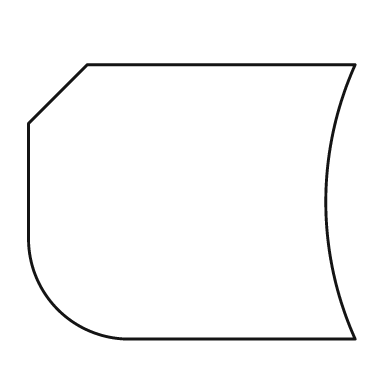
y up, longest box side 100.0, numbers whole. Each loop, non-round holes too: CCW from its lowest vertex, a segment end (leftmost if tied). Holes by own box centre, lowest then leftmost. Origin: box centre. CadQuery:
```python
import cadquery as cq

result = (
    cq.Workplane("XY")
    .moveTo(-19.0, -42.0)
    .lineTo(50.0, -42.0)
    .threePointArc((41.0, 0.0), (50.0, 42.0))
    .lineTo(-32.0, 42.0)
    .lineTo(-50.0, 24.0)
    .lineTo(-50.0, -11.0)
    .threePointArc((-41.0, -33.0), (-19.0, -42.0))
    .close()
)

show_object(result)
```